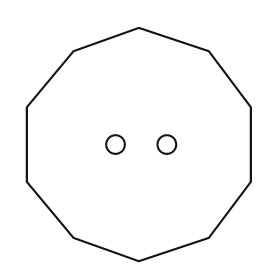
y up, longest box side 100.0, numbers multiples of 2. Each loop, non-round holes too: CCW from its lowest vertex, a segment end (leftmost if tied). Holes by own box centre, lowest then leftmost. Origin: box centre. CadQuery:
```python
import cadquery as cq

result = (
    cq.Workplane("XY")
    .moveTo(0.0, -50.0)
    .lineTo(30.0, -40.0)
    .lineTo(48.0, -16.0)
    .lineTo(48.0, 16.0)
    .lineTo(30.0, 40.0)
    .lineTo(0.0, 50.0)
    .lineTo(-28.0, 40.0)
    .lineTo(-48.0, 16.0)
    .lineTo(-48.0, -16.0)
    .lineTo(-28.0, -40.0)
    .close()
    .moveTo(-10.0, 0.0)
    .circle(4.0)
    .moveTo(12.0, 0.0)
    .circle(4.0)
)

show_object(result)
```